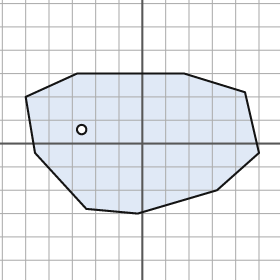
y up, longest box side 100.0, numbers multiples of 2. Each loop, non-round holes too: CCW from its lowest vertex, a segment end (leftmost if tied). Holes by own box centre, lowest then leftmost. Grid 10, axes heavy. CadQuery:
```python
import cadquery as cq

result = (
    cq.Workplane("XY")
    .moveTo(-2.0, -30.0)
    .lineTo(32.0, -20.0)
    .lineTo(50.0, -4.0)
    .lineTo(44.0, 22.0)
    .lineTo(18.0, 30.0)
    .lineTo(-28.0, 30.0)
    .lineTo(-50.0, 20.0)
    .lineTo(-46.0, -4.0)
    .lineTo(-24.0, -28.0)
    .close()
    .moveTo(-26.0, 6.0)
    .circle(2.0)
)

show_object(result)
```